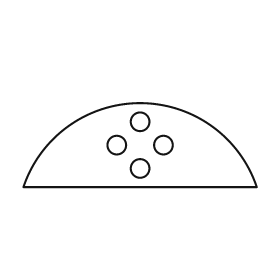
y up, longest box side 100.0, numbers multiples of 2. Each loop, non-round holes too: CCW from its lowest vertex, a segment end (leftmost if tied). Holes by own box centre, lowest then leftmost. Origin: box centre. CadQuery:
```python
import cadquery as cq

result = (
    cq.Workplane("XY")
    .moveTo(-50.0, -18.0)
    .lineTo(50.0, -18.0)
    .threePointArc((0.0, 18.0), (-50.0, -18.0))
    .close()
    .moveTo(0.0, -10.0)
    .circle(4.0)
    .moveTo(-10.0, 0.0)
    .circle(4.0)
    .moveTo(10.0, 0.0)
    .circle(4.0)
    .moveTo(0.0, 10.0)
    .circle(4.0)
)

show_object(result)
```